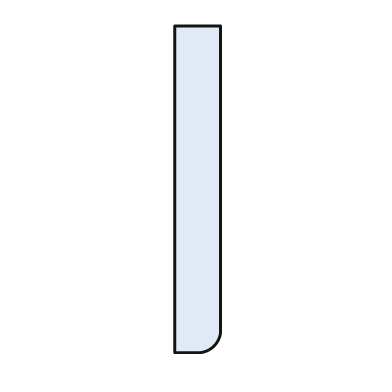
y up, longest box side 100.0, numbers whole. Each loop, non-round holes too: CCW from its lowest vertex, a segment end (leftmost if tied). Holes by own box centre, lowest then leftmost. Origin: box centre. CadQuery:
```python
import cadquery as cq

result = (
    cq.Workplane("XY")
    .moveTo(-7.0, -50.0)
    .lineTo(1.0, -50.0)
    .threePointArc((5.0, -48.0), (7.0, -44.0))
    .lineTo(7.0, 50.0)
    .lineTo(-7.0, 50.0)
    .close()
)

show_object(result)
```